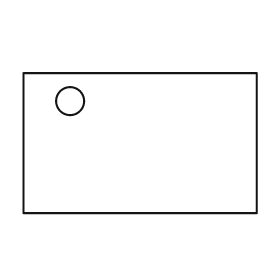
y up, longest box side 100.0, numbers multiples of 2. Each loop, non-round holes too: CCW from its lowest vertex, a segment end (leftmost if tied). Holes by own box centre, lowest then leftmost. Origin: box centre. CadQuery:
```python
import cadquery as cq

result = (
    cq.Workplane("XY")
    .moveTo(-50.0, -30.0)
    .lineTo(50.0, -30.0)
    .lineTo(50.0, 30.0)
    .lineTo(-50.0, 30.0)
    .close()
    .moveTo(-30.0, 18.0)
    .circle(6.0)
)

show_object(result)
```